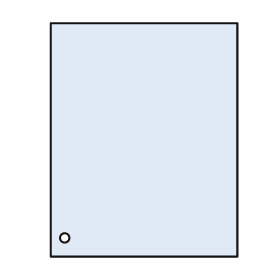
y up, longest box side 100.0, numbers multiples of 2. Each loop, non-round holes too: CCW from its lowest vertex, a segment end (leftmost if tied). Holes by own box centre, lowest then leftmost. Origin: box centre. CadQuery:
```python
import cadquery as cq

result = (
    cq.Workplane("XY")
    .moveTo(-40.0, -50.0)
    .lineTo(40.0, -50.0)
    .lineTo(40.0, 50.0)
    .lineTo(-40.0, 50.0)
    .close()
    .moveTo(-34.0, -42.0)
    .circle(2.0)
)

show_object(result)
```